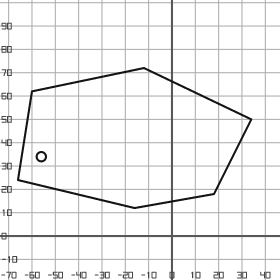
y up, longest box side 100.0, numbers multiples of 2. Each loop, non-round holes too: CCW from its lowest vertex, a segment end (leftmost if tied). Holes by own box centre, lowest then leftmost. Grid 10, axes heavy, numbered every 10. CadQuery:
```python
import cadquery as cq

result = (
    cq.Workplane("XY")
    .moveTo(-16.0, 12.0)
    .lineTo(18.0, 18.0)
    .lineTo(34.0, 50.0)
    .lineTo(-12.0, 72.0)
    .lineTo(-60.0, 62.0)
    .lineTo(-66.0, 24.0)
    .close()
    .moveTo(-56.0, 34.0)
    .circle(2.0)
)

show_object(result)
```